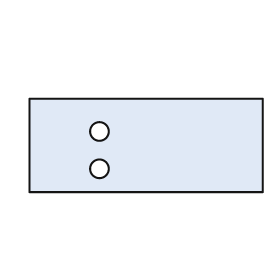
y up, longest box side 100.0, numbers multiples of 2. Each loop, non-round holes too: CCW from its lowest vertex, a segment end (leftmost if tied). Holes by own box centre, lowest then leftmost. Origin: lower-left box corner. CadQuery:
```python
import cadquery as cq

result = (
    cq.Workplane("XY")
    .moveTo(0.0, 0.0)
    .lineTo(100.0, 0.0)
    .lineTo(100.0, 40.0)
    .lineTo(0.0, 40.0)
    .close()
    .moveTo(30.0, 10.0)
    .circle(4.0)
    .moveTo(30.0, 26.0)
    .circle(4.0)
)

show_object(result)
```